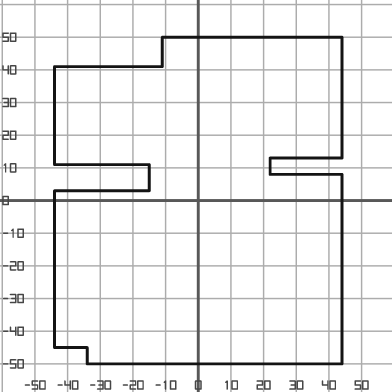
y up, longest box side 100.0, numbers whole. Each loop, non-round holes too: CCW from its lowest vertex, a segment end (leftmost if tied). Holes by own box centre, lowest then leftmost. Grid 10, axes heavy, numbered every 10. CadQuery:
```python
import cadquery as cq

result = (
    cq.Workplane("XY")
    .moveTo(-34.0, -50.0)
    .lineTo(44.0, -50.0)
    .lineTo(44.0, 8.0)
    .lineTo(22.0, 8.0)
    .lineTo(22.0, 13.0)
    .lineTo(44.0, 13.0)
    .lineTo(44.0, 50.0)
    .lineTo(-11.0, 50.0)
    .lineTo(-11.0, 41.0)
    .lineTo(-44.0, 41.0)
    .lineTo(-44.0, 11.0)
    .lineTo(-15.0, 11.0)
    .lineTo(-15.0, 3.0)
    .lineTo(-44.0, 3.0)
    .lineTo(-44.0, -45.0)
    .lineTo(-34.0, -45.0)
    .close()
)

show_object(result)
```